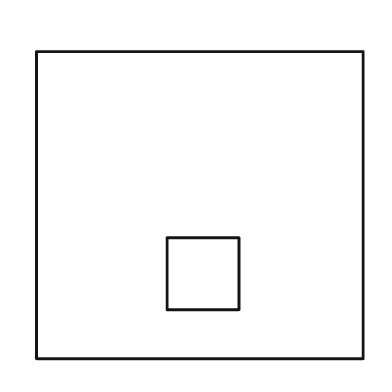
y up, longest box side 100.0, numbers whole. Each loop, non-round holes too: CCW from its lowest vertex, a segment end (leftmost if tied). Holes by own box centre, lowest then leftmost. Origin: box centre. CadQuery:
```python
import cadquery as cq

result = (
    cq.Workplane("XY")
    .moveTo(-50.0, -47.0)
    .lineTo(50.0, -47.0)
    .lineTo(50.0, 47.0)
    .lineTo(-50.0, 47.0)
    .close()
    .moveTo(-10.0, -32.0)
    .lineTo(12.0, -32.0)
    .lineTo(12.0, -10.0)
    .lineTo(-10.0, -10.0)
    .close()
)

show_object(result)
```